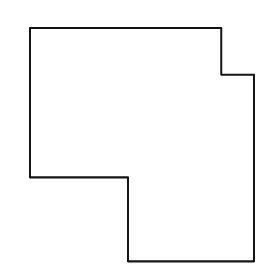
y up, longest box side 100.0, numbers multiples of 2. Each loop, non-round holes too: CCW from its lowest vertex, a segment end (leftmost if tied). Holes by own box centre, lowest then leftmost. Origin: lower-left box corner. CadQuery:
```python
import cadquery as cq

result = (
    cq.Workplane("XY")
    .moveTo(42.0, 0.0)
    .lineTo(96.0, 0.0)
    .lineTo(96.0, 80.0)
    .lineTo(82.0, 80.0)
    .lineTo(82.0, 100.0)
    .lineTo(0.0, 100.0)
    .lineTo(0.0, 36.0)
    .lineTo(42.0, 36.0)
    .close()
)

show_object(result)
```